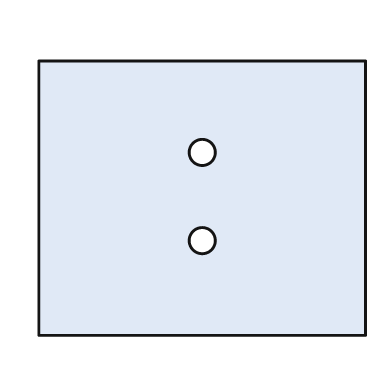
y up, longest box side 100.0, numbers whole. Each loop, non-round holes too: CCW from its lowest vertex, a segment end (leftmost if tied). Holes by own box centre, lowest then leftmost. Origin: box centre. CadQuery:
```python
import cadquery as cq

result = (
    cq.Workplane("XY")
    .moveTo(-50.0, -42.0)
    .lineTo(50.0, -42.0)
    .lineTo(50.0, 42.0)
    .lineTo(-50.0, 42.0)
    .close()
    .moveTo(0.0, -13.0)
    .circle(4.0)
    .moveTo(0.0, 14.0)
    .circle(4.0)
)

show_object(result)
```